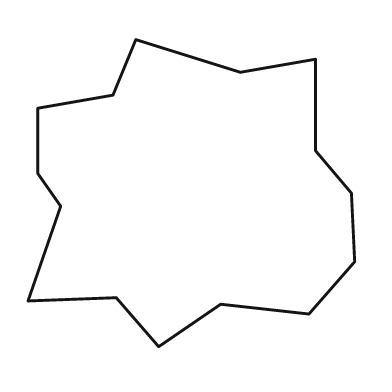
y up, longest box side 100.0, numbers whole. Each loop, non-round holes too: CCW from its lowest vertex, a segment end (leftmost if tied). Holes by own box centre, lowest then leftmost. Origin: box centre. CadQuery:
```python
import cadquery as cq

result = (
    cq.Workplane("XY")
    .moveTo(-10.0, -47.0)
    .lineTo(9.0, -34.0)
    .lineTo(36.0, -37.0)
    .lineTo(50.0, -21.0)
    .lineTo(49.0, 0.0)
    .lineTo(38.0, 13.0)
    .lineTo(38.0, 41.0)
    .lineTo(15.0, 37.0)
    .lineTo(-17.0, 47.0)
    .lineTo(-24.0, 30.0)
    .lineTo(-47.0, 26.0)
    .lineTo(-47.0, 6.0)
    .lineTo(-40.0, -4.0)
    .lineTo(-50.0, -33.0)
    .lineTo(-23.0, -32.0)
    .close()
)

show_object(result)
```